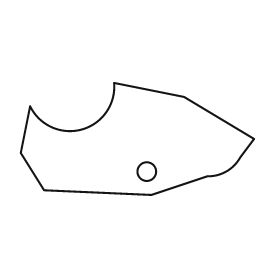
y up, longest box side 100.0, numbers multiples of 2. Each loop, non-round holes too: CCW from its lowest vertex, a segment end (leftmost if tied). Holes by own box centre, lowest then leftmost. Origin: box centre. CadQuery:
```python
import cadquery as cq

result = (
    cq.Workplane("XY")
    .moveTo(6.0, -24.0)
    .lineTo(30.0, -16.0)
    .threePointArc((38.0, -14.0), (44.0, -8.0))
    .lineTo(50.0, 0.0)
    .lineTo(20.0, 18.0)
    .lineTo(-10.0, 24.0)
    .threePointArc((-24.0, 4.0), (-46.0, 14.0))
    .lineTo(-50.0, -6.0)
    .lineTo(-40.0, -22.0)
    .close()
    .moveTo(4.0, -14.0)
    .circle(4.0)
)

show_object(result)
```